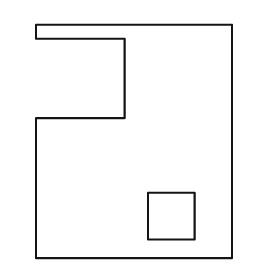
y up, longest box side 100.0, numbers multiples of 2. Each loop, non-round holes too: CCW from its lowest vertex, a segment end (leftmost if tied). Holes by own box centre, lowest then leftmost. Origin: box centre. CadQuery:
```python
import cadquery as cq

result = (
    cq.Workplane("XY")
    .moveTo(-42.0, -50.0)
    .lineTo(42.0, -50.0)
    .lineTo(42.0, 50.0)
    .lineTo(-42.0, 50.0)
    .lineTo(-42.0, 44.0)
    .lineTo(-4.0, 44.0)
    .lineTo(-4.0, 10.0)
    .lineTo(-42.0, 10.0)
    .close()
    .moveTo(6.0, -42.0)
    .lineTo(26.0, -42.0)
    .lineTo(26.0, -22.0)
    .lineTo(6.0, -22.0)
    .close()
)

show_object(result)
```